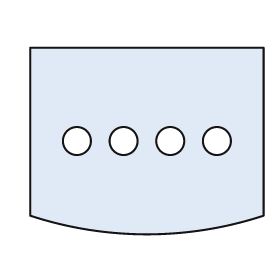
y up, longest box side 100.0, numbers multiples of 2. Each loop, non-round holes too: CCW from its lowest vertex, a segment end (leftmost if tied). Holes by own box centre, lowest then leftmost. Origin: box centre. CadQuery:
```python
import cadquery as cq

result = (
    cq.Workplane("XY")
    .moveTo(-50.0, -32.0)
    .threePointArc((0.0, -40.0), (50.0, -32.0))
    .lineTo(50.0, 40.0)
    .lineTo(-50.0, 40.0)
    .close()
    .moveTo(-30.0, 0.0)
    .circle(6.0)
    .moveTo(-10.0, 0.0)
    .circle(6.0)
    .moveTo(10.0, 0.0)
    .circle(6.0)
    .moveTo(30.0, 0.0)
    .circle(6.0)
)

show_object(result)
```